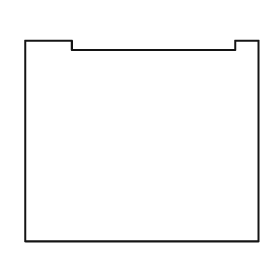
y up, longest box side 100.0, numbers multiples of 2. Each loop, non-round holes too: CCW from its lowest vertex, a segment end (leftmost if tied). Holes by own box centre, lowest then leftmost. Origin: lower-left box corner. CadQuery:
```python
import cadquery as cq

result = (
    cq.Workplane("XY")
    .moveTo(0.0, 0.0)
    .lineTo(100.0, 0.0)
    .lineTo(100.0, 86.0)
    .lineTo(90.0, 86.0)
    .lineTo(90.0, 82.0)
    .lineTo(20.0, 82.0)
    .lineTo(20.0, 86.0)
    .lineTo(0.0, 86.0)
    .close()
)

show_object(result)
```